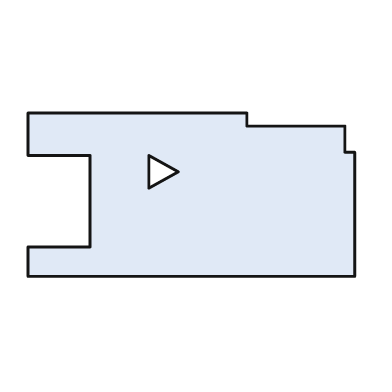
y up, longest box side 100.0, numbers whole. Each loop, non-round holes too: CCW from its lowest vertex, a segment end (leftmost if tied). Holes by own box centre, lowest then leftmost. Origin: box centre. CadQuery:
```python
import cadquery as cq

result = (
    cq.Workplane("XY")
    .moveTo(-50.0, -25.0)
    .lineTo(50.0, -25.0)
    .lineTo(50.0, 13.0)
    .lineTo(47.0, 13.0)
    .lineTo(47.0, 21.0)
    .lineTo(17.0, 21.0)
    .lineTo(17.0, 25.0)
    .lineTo(-50.0, 25.0)
    .lineTo(-50.0, 12.0)
    .lineTo(-31.0, 12.0)
    .lineTo(-31.0, -16.0)
    .lineTo(-50.0, -16.0)
    .close()
    .moveTo(-13.0, 2.0)
    .lineTo(-4.0, 7.0)
    .lineTo(-13.0, 12.0)
    .close()
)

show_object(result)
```